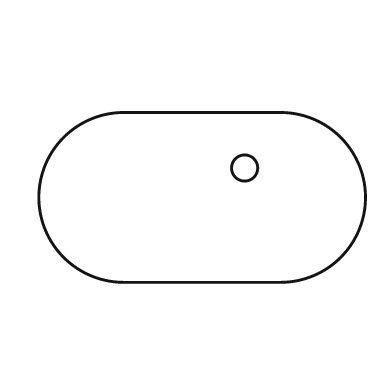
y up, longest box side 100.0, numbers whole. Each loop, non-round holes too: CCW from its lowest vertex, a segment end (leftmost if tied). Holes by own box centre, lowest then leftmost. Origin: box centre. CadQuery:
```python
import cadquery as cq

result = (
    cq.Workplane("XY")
    .moveTo(-24.0, -26.0)
    .lineTo(24.0, -26.0)
    .threePointArc((50.0, 0.0), (24.0, 26.0))
    .lineTo(-24.0, 26.0)
    .threePointArc((-50.0, 0.0), (-24.0, -26.0))
    .close()
    .moveTo(13.0, 9.0)
    .circle(4.0)
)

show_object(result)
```